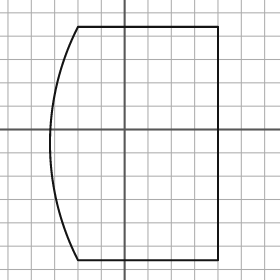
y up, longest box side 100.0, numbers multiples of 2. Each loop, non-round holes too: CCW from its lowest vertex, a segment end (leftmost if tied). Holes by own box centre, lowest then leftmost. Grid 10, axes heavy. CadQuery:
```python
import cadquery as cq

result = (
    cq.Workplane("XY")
    .moveTo(-20.0, -56.0)
    .lineTo(40.0, -56.0)
    .lineTo(40.0, 44.0)
    .lineTo(-20.0, 44.0)
    .threePointArc((-32.0, -6.0), (-20.0, -56.0))
    .close()
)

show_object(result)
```